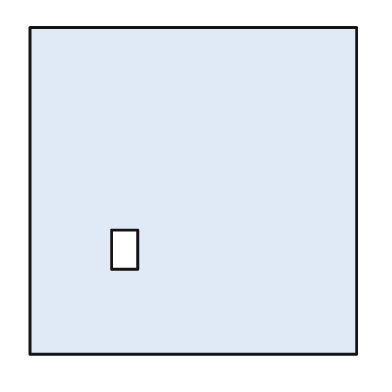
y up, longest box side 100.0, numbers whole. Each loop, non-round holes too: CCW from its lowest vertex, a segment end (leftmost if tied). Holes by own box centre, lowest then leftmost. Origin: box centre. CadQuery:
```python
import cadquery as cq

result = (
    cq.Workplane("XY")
    .moveTo(-50.0, -50.0)
    .lineTo(50.0, -50.0)
    .lineTo(50.0, 50.0)
    .lineTo(-50.0, 50.0)
    .close()
    .moveTo(-25.0, -24.0)
    .lineTo(-17.0, -24.0)
    .lineTo(-17.0, -12.0)
    .lineTo(-25.0, -12.0)
    .close()
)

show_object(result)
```